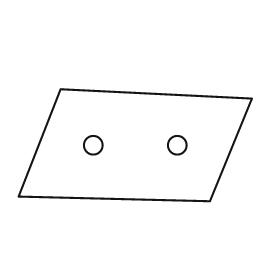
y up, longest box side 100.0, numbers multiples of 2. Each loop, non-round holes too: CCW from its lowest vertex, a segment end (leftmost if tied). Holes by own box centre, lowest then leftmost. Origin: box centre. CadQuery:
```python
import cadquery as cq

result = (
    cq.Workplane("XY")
    .moveTo(32.0, -24.0)
    .lineTo(50.0, 20.0)
    .lineTo(-32.0, 24.0)
    .lineTo(-50.0, -22.0)
    .close()
    .moveTo(-18.0, 0.0)
    .circle(4.0)
    .moveTo(18.0, 0.0)
    .circle(4.0)
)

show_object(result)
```